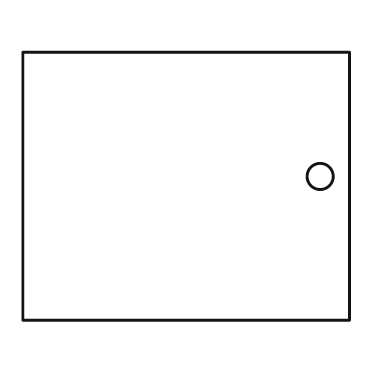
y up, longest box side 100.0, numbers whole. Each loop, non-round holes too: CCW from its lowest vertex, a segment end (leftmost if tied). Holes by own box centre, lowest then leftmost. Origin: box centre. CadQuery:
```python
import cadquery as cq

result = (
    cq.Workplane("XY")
    .moveTo(-50.0, -41.0)
    .lineTo(50.0, -41.0)
    .lineTo(50.0, 41.0)
    .lineTo(-50.0, 41.0)
    .close()
    .moveTo(41.0, 3.0)
    .circle(4.0)
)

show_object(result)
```